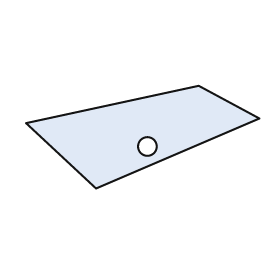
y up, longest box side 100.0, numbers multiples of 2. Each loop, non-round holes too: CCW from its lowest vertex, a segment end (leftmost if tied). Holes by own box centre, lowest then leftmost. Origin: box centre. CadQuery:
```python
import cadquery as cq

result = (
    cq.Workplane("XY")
    .moveTo(-20.0, -22.0)
    .lineTo(50.0, 8.0)
    .lineTo(24.0, 22.0)
    .lineTo(-50.0, 6.0)
    .close()
    .moveTo(2.0, -4.0)
    .circle(4.0)
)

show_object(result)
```